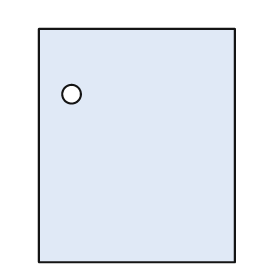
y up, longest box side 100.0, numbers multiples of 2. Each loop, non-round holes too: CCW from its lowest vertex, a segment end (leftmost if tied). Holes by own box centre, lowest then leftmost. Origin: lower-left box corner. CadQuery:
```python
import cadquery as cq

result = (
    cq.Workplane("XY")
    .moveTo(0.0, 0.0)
    .lineTo(84.0, 0.0)
    .lineTo(84.0, 100.0)
    .lineTo(0.0, 100.0)
    .close()
    .moveTo(14.0, 72.0)
    .circle(4.0)
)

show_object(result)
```